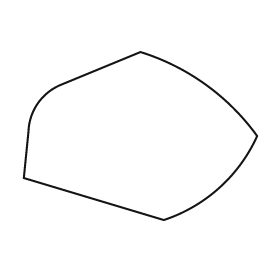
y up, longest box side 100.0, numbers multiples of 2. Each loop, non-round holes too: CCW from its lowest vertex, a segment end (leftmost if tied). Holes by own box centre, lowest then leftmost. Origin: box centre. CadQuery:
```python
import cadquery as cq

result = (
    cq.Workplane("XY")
    .moveTo(10.0, -36.0)
    .threePointArc((34.0, -22.0), (50.0, 0.0))
    .threePointArc((28.0, 22.0), (0.0, 36.0))
    .lineTo(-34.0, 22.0)
    .threePointArc((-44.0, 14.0), (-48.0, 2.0))
    .lineTo(-50.0, -18.0)
    .close()
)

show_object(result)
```